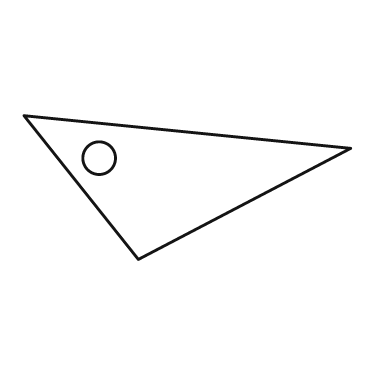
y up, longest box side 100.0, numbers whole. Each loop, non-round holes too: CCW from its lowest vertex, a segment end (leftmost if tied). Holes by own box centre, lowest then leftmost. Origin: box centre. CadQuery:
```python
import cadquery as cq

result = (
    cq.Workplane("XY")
    .moveTo(-15.0, -22.0)
    .lineTo(50.0, 12.0)
    .lineTo(-50.0, 22.0)
    .close()
    .moveTo(-27.0, 9.0)
    .circle(5.0)
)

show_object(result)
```